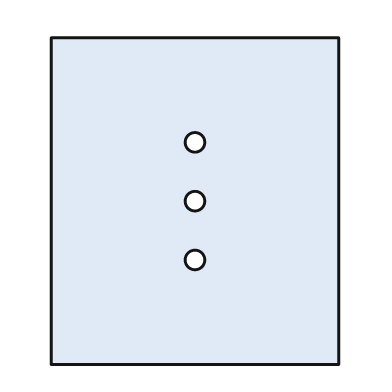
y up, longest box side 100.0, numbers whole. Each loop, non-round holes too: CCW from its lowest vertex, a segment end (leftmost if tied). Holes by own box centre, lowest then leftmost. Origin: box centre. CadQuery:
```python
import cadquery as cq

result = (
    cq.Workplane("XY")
    .moveTo(-44.0, -50.0)
    .lineTo(44.0, -50.0)
    .lineTo(44.0, 50.0)
    .lineTo(-44.0, 50.0)
    .close()
    .moveTo(0.0, -18.0)
    .circle(3.0)
    .moveTo(0.0, 0.0)
    .circle(3.0)
    .moveTo(0.0, 18.0)
    .circle(3.0)
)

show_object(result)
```